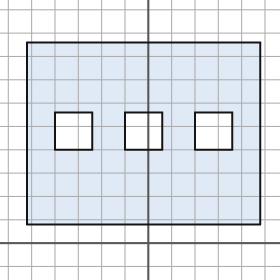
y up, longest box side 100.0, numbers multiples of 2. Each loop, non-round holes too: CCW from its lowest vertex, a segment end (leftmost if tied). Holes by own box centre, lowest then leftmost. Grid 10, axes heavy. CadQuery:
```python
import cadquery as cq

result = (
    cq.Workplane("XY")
    .moveTo(-52.0, 8.0)
    .lineTo(48.0, 8.0)
    .lineTo(48.0, 86.0)
    .lineTo(-52.0, 86.0)
    .close()
    .moveTo(-40.0, 40.0)
    .lineTo(-24.0, 40.0)
    .lineTo(-24.0, 56.0)
    .lineTo(-40.0, 56.0)
    .close()
    .moveTo(-10.0, 40.0)
    .lineTo(6.0, 40.0)
    .lineTo(6.0, 56.0)
    .lineTo(-10.0, 56.0)
    .close()
    .moveTo(20.0, 40.0)
    .lineTo(36.0, 40.0)
    .lineTo(36.0, 56.0)
    .lineTo(20.0, 56.0)
    .close()
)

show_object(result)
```